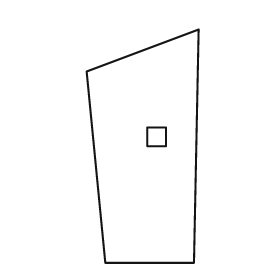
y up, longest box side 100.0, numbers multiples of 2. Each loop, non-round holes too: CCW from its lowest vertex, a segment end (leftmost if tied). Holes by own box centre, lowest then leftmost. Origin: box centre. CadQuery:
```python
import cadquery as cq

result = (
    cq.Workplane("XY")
    .moveTo(-16.0, -50.0)
    .lineTo(22.0, -50.0)
    .lineTo(24.0, 50.0)
    .lineTo(-24.0, 32.0)
    .close()
    .moveTo(2.0, 0.0)
    .lineTo(10.0, 0.0)
    .lineTo(10.0, 8.0)
    .lineTo(2.0, 8.0)
    .close()
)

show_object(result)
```